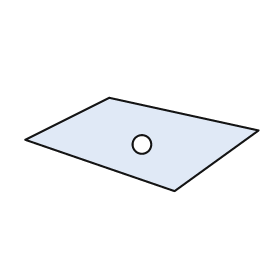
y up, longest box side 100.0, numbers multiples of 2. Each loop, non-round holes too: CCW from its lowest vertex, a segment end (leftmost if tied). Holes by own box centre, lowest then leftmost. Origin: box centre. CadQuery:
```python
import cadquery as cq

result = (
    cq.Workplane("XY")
    .moveTo(14.0, -20.0)
    .lineTo(50.0, 6.0)
    .lineTo(-14.0, 20.0)
    .lineTo(-50.0, 2.0)
    .close()
    .moveTo(0.0, 0.0)
    .circle(4.0)
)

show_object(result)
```